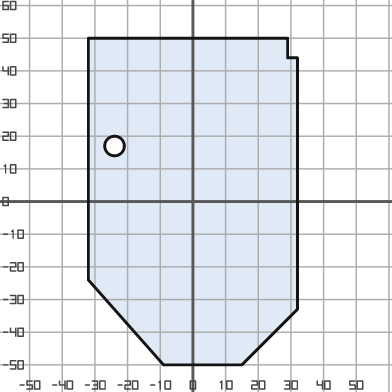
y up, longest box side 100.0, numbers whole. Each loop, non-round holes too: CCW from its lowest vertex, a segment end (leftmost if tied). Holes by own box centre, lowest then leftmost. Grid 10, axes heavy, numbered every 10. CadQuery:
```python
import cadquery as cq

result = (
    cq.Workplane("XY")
    .moveTo(-9.0, -50.0)
    .lineTo(15.0, -50.0)
    .lineTo(32.0, -33.0)
    .lineTo(32.0, 44.0)
    .lineTo(29.0, 44.0)
    .lineTo(29.0, 50.0)
    .lineTo(-32.0, 50.0)
    .lineTo(-32.0, -24.0)
    .close()
    .moveTo(-24.0, 17.0)
    .circle(3.0)
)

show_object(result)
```